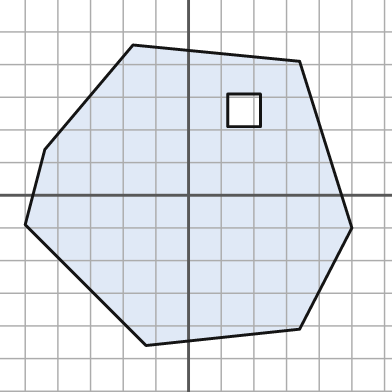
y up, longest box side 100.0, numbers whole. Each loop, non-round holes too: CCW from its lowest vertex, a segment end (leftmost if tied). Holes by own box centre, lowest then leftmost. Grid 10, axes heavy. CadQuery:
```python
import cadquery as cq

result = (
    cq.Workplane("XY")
    .moveTo(-13.0, -46.0)
    .lineTo(34.0, -41.0)
    .lineTo(50.0, -10.0)
    .lineTo(34.0, 41.0)
    .lineTo(-17.0, 46.0)
    .lineTo(-44.0, 14.0)
    .lineTo(-50.0, -9.0)
    .close()
    .moveTo(12.0, 21.0)
    .lineTo(22.0, 21.0)
    .lineTo(22.0, 31.0)
    .lineTo(12.0, 31.0)
    .close()
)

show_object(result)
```